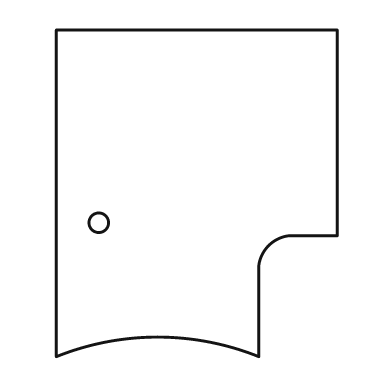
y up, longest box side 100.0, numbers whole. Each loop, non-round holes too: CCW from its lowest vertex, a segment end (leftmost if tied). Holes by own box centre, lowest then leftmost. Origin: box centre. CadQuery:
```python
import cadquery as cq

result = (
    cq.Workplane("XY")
    .moveTo(-43.0, -50.0)
    .threePointArc((-12.0, -44.0), (19.0, -50.0))
    .lineTo(19.0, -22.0)
    .threePointArc((22.0, -16.0), (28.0, -13.0))
    .lineTo(43.0, -13.0)
    .lineTo(43.0, 50.0)
    .lineTo(-43.0, 50.0)
    .close()
    .moveTo(-30.0, -9.0)
    .circle(3.0)
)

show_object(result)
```